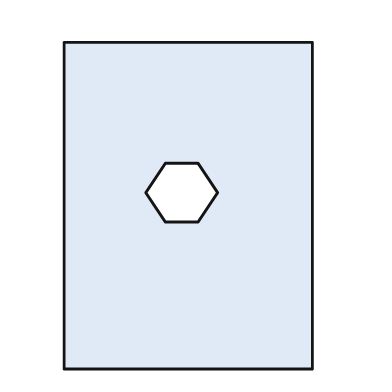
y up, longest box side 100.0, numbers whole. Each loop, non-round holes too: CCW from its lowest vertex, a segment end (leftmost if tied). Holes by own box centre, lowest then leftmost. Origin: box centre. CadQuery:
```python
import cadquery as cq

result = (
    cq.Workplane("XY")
    .moveTo(-38.0, -50.0)
    .lineTo(38.0, -50.0)
    .lineTo(38.0, 50.0)
    .lineTo(-38.0, 50.0)
    .close()
    .moveTo(-7.0, -5.0)
    .lineTo(3.0, -5.0)
    .lineTo(9.0, 4.0)
    .lineTo(3.0, 13.0)
    .lineTo(-7.0, 13.0)
    .lineTo(-13.0, 4.0)
    .close()
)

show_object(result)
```